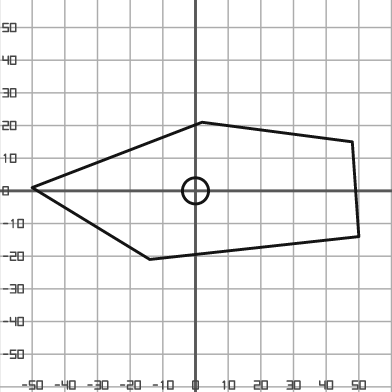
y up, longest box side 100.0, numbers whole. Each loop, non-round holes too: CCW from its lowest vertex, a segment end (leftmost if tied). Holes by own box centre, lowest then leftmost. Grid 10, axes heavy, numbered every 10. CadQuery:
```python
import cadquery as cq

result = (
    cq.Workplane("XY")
    .moveTo(-14.0, -21.0)
    .lineTo(50.0, -14.0)
    .lineTo(48.0, 15.0)
    .lineTo(2.0, 21.0)
    .lineTo(-50.0, 1.0)
    .close()
    .moveTo(0.0, 0.0)
    .circle(4.0)
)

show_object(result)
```